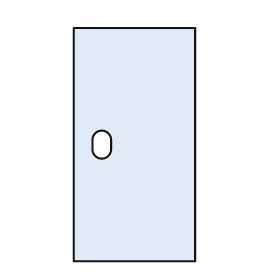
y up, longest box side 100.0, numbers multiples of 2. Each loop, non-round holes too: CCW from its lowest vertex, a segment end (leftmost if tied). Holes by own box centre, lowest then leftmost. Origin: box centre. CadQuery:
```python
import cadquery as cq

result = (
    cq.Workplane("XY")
    .moveTo(-26.0, -50.0)
    .lineTo(26.0, -50.0)
    .lineTo(26.0, 50.0)
    .lineTo(-26.0, 50.0)
    .close()
    .moveTo(-18.0, -2.0)
    .threePointArc((-14.0, -6.0), (-10.0, -2.0))
    .lineTo(-10.0, 2.0)
    .threePointArc((-14.0, 6.0), (-18.0, 2.0))
    .close()
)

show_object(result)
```